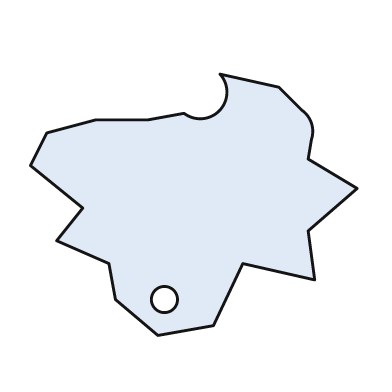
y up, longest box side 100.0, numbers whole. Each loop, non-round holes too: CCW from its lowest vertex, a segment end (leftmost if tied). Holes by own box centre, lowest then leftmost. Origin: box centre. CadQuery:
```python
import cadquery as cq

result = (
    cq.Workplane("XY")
    .moveTo(-11.0, -40.0)
    .lineTo(6.0, -37.0)
    .lineTo(15.0, -18.0)
    .lineTo(37.0, -23.0)
    .lineTo(35.0, -8.0)
    .lineTo(50.0, 5.0)
    .lineTo(35.0, 14.0)
    .lineTo(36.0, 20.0)
    .threePointArc((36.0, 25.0), (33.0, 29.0))
    .lineTo(26.0, 36.0)
    .lineTo(8.0, 40.0)
    .threePointArc((8.0, 29.0), (-3.0, 28.0))
    .lineTo(-14.0, 26.0)
    .lineTo(-30.0, 26.0)
    .lineTo(-45.0, 22.0)
    .lineTo(-50.0, 12.0)
    .lineTo(-34.0, -1.0)
    .lineTo(-42.0, -11.0)
    .lineTo(-26.0, -18.0)
    .lineTo(-24.0, -29.0)
    .close()
    .moveTo(-9.0, -29.0)
    .circle(4.0)
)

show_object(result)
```